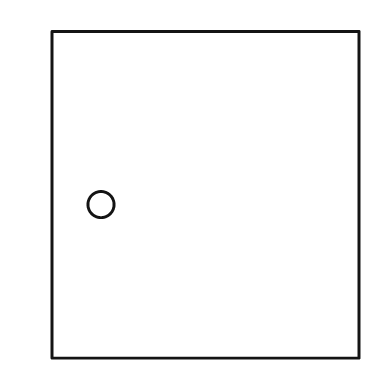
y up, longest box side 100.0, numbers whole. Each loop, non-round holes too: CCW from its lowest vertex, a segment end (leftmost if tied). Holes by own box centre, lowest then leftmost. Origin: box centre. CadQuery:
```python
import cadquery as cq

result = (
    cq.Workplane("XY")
    .moveTo(-47.0, -50.0)
    .lineTo(47.0, -50.0)
    .lineTo(47.0, 50.0)
    .lineTo(-47.0, 50.0)
    .close()
    .moveTo(-32.0, -3.0)
    .circle(4.0)
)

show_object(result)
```